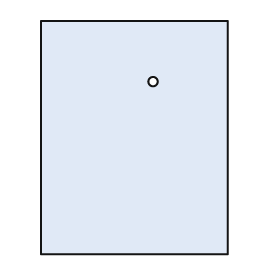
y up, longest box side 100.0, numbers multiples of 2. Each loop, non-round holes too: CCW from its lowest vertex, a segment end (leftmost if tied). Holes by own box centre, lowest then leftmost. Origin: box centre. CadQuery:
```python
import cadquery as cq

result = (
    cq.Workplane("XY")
    .moveTo(-40.0, -50.0)
    .lineTo(40.0, -50.0)
    .lineTo(40.0, 50.0)
    .lineTo(-40.0, 50.0)
    .close()
    .moveTo(8.0, 24.0)
    .circle(2.0)
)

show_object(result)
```